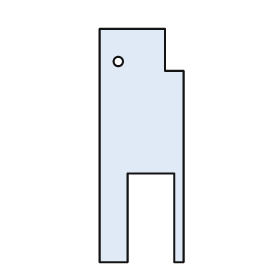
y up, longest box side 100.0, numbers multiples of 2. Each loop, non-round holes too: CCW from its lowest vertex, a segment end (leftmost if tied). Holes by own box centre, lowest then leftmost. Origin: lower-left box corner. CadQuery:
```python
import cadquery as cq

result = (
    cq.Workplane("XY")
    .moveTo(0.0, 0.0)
    .lineTo(12.0, 0.0)
    .lineTo(12.0, 38.0)
    .lineTo(32.0, 38.0)
    .lineTo(32.0, 0.0)
    .lineTo(36.0, 0.0)
    .lineTo(36.0, 82.0)
    .lineTo(28.0, 82.0)
    .lineTo(28.0, 100.0)
    .lineTo(0.0, 100.0)
    .close()
    .moveTo(8.0, 86.0)
    .circle(2.0)
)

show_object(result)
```